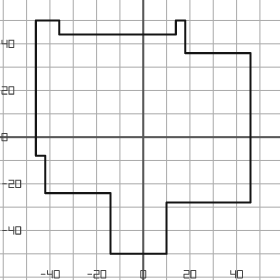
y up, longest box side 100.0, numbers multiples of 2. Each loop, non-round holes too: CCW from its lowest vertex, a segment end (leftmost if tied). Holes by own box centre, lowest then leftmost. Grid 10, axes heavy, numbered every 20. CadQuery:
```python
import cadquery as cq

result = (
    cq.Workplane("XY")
    .moveTo(-14.0, -50.0)
    .lineTo(10.0, -50.0)
    .lineTo(10.0, -28.0)
    .lineTo(46.0, -28.0)
    .lineTo(46.0, 36.0)
    .lineTo(18.0, 36.0)
    .lineTo(18.0, 50.0)
    .lineTo(14.0, 50.0)
    .lineTo(14.0, 44.0)
    .lineTo(-36.0, 44.0)
    .lineTo(-36.0, 50.0)
    .lineTo(-46.0, 50.0)
    .lineTo(-46.0, -8.0)
    .lineTo(-42.0, -8.0)
    .lineTo(-42.0, -24.0)
    .lineTo(-14.0, -24.0)
    .close()
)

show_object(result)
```